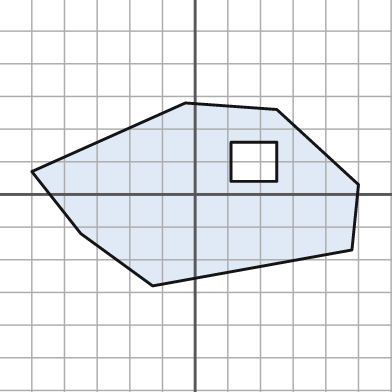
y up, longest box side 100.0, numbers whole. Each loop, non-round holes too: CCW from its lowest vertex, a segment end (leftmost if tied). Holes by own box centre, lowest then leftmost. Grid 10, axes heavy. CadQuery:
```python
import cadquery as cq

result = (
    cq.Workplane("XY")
    .moveTo(-13.0, -28.0)
    .lineTo(48.0, -17.0)
    .lineTo(50.0, 3.0)
    .lineTo(25.0, 26.0)
    .lineTo(-3.0, 28.0)
    .lineTo(-50.0, 7.0)
    .lineTo(-35.0, -12.0)
    .close()
    .moveTo(11.0, 4.0)
    .lineTo(25.0, 4.0)
    .lineTo(25.0, 16.0)
    .lineTo(11.0, 16.0)
    .close()
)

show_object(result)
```